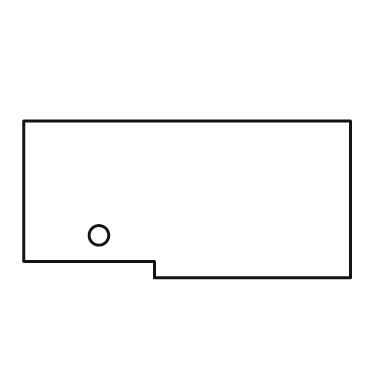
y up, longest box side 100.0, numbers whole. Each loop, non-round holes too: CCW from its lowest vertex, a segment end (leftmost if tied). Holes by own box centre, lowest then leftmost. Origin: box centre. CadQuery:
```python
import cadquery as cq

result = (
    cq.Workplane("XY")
    .moveTo(-10.0, -24.0)
    .lineTo(50.0, -24.0)
    .lineTo(50.0, 24.0)
    .lineTo(-50.0, 24.0)
    .lineTo(-50.0, -19.0)
    .lineTo(-10.0, -19.0)
    .close()
    .moveTo(-27.0, -11.0)
    .circle(3.0)
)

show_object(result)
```